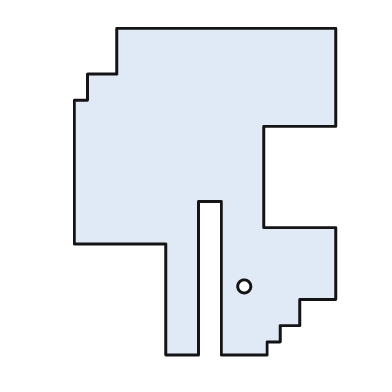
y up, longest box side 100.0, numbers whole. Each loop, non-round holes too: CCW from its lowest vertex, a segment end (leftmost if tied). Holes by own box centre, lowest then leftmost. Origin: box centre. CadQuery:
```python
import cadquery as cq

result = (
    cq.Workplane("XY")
    .moveTo(-12.0, -50.0)
    .lineTo(-2.0, -50.0)
    .lineTo(-2.0, -3.0)
    .lineTo(5.0, -3.0)
    .lineTo(5.0, -50.0)
    .lineTo(19.0, -50.0)
    .lineTo(19.0, -46.0)
    .lineTo(23.0, -46.0)
    .lineTo(23.0, -41.0)
    .lineTo(29.0, -41.0)
    .lineTo(29.0, -33.0)
    .lineTo(40.0, -33.0)
    .lineTo(40.0, -11.0)
    .lineTo(18.0, -11.0)
    .lineTo(18.0, 20.0)
    .lineTo(40.0, 20.0)
    .lineTo(40.0, 50.0)
    .lineTo(-27.0, 50.0)
    .lineTo(-27.0, 36.0)
    .lineTo(-36.0, 36.0)
    .lineTo(-36.0, 28.0)
    .lineTo(-40.0, 28.0)
    .lineTo(-40.0, -16.0)
    .lineTo(-12.0, -16.0)
    .close()
    .moveTo(12.0, -29.0)
    .circle(2.0)
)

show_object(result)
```